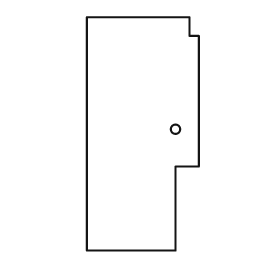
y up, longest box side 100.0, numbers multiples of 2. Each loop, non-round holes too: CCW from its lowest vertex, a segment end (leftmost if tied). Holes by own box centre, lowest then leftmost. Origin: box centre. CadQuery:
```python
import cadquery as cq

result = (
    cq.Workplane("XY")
    .moveTo(-24.0, -50.0)
    .lineTo(14.0, -50.0)
    .lineTo(14.0, -14.0)
    .lineTo(24.0, -14.0)
    .lineTo(24.0, 42.0)
    .lineTo(20.0, 42.0)
    .lineTo(20.0, 50.0)
    .lineTo(-24.0, 50.0)
    .close()
    .moveTo(14.0, 2.0)
    .circle(2.0)
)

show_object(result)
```